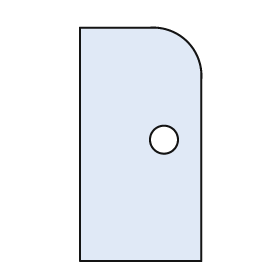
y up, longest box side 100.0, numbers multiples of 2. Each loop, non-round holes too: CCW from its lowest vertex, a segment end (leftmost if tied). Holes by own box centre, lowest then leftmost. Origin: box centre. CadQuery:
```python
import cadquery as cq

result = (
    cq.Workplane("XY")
    .moveTo(-26.0, -50.0)
    .lineTo(26.0, -50.0)
    .lineTo(26.0, 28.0)
    .threePointArc((20.0, 44.0), (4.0, 50.0))
    .lineTo(-26.0, 50.0)
    .close()
    .moveTo(10.0, 2.0)
    .circle(6.0)
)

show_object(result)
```